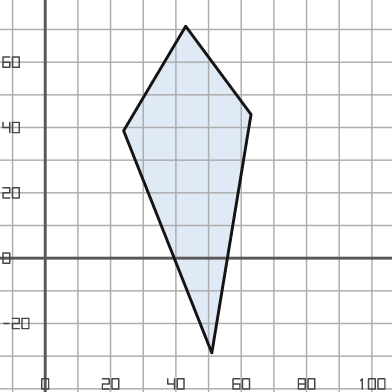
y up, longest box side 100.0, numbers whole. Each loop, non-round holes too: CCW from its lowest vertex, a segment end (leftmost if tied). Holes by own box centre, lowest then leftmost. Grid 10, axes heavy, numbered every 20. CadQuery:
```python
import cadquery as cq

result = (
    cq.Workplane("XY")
    .moveTo(51.0, -29.0)
    .lineTo(63.0, 44.0)
    .lineTo(43.0, 71.0)
    .lineTo(24.0, 39.0)
    .close()
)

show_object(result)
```